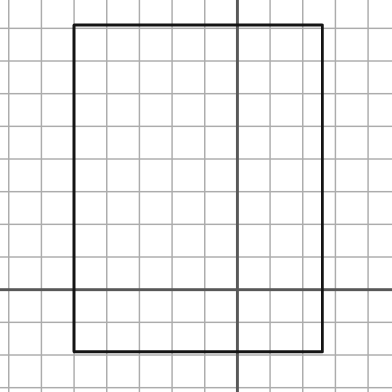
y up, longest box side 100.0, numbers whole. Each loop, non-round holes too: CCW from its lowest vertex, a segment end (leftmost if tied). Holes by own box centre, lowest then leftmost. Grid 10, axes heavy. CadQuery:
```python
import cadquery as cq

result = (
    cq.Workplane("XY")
    .moveTo(-50.0, -19.0)
    .lineTo(26.0, -19.0)
    .lineTo(26.0, 81.0)
    .lineTo(-50.0, 81.0)
    .close()
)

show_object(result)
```